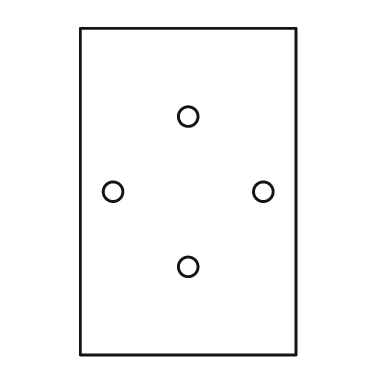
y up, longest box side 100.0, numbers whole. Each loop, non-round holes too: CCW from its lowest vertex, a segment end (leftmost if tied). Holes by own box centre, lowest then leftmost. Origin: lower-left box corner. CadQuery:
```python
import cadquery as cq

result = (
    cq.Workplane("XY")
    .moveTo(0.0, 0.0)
    .lineTo(66.0, 0.0)
    .lineTo(66.0, 100.0)
    .lineTo(0.0, 100.0)
    .close()
    .moveTo(33.0, 27.0)
    .circle(3.0)
    .moveTo(10.0, 50.0)
    .circle(3.0)
    .moveTo(56.0, 50.0)
    .circle(3.0)
    .moveTo(33.0, 73.0)
    .circle(3.0)
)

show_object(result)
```